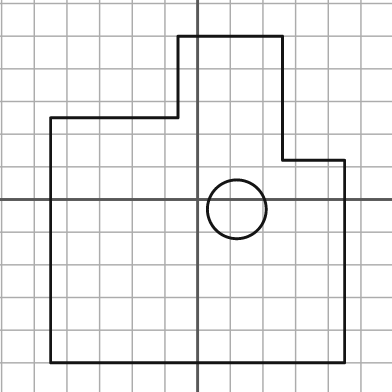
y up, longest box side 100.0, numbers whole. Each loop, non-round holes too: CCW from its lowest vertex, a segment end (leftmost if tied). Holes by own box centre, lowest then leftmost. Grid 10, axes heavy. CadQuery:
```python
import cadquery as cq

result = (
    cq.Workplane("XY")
    .moveTo(-45.0, -50.0)
    .lineTo(45.0, -50.0)
    .lineTo(45.0, 12.0)
    .lineTo(26.0, 12.0)
    .lineTo(26.0, 50.0)
    .lineTo(-6.0, 50.0)
    .lineTo(-6.0, 25.0)
    .lineTo(-45.0, 25.0)
    .close()
    .moveTo(12.0, -3.0)
    .circle(9.0)
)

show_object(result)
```